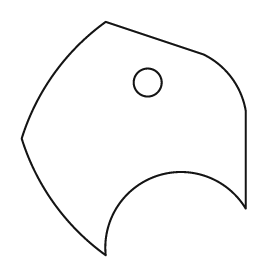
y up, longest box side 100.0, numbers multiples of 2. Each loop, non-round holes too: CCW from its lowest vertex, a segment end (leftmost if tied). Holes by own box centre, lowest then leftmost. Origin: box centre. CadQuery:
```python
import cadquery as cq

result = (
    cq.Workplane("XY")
    .moveTo(-12.0, -50.0)
    .threePointArc((10.0, -16.0), (48.0, -30.0))
    .lineTo(48.0, 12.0)
    .threePointArc((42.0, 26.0), (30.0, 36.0))
    .lineTo(-12.0, 50.0)
    .threePointArc((-34.0, 28.0), (-48.0, 0.0))
    .threePointArc((-34.0, -28.0), (-12.0, -50.0))
    .close()
    .moveTo(6.0, 24.0)
    .circle(6.0)
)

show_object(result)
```